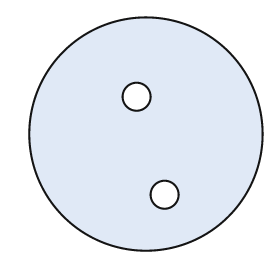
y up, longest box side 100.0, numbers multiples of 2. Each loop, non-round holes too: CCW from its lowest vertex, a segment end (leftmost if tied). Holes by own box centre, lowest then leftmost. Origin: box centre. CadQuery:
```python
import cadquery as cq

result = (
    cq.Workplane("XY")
    .moveTo(0.0, 0.0)
    .circle(50.0)
    .moveTo(8.0, -26.0)
    .circle(6.0)
    .moveTo(-4.0, 16.0)
    .circle(6.0)
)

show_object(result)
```